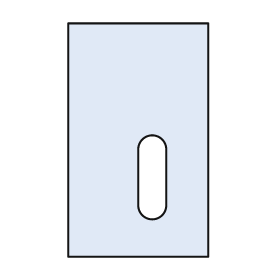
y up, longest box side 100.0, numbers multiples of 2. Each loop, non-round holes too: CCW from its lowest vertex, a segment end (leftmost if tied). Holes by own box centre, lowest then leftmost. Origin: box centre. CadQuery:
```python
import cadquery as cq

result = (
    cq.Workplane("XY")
    .moveTo(-30.0, -50.0)
    .lineTo(30.0, -50.0)
    .lineTo(30.0, 50.0)
    .lineTo(-30.0, 50.0)
    .close()
    .moveTo(0.0, -28.0)
    .threePointArc((6.0, -34.0), (12.0, -28.0))
    .lineTo(12.0, -4.0)
    .threePointArc((6.0, 2.0), (0.0, -4.0))
    .close()
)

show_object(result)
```